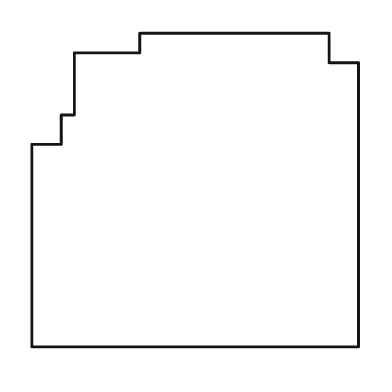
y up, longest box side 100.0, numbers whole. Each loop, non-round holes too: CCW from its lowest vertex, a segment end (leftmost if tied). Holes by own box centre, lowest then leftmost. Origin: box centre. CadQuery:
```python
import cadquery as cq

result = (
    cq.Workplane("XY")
    .moveTo(-50.0, -48.0)
    .lineTo(50.0, -48.0)
    .lineTo(50.0, 39.0)
    .lineTo(41.0, 39.0)
    .lineTo(41.0, 48.0)
    .lineTo(-17.0, 48.0)
    .lineTo(-17.0, 42.0)
    .lineTo(-37.0, 42.0)
    .lineTo(-37.0, 23.0)
    .lineTo(-41.0, 23.0)
    .lineTo(-41.0, 14.0)
    .lineTo(-50.0, 14.0)
    .close()
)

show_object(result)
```